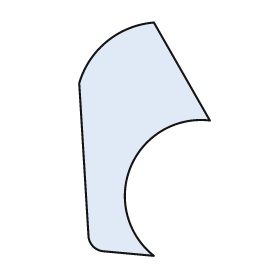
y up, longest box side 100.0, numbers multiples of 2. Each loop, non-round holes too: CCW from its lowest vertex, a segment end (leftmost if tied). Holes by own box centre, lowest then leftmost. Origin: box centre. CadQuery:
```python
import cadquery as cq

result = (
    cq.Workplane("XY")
    .moveTo(4.0, -50.0)
    .threePointArc((-6.0, -12.0), (28.0, 8.0))
    .lineTo(4.0, 50.0)
    .threePointArc((-16.0, 42.0), (-28.0, 24.0))
    .lineTo(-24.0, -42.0)
    .threePointArc((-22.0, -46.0), (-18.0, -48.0))
    .close()
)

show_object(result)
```